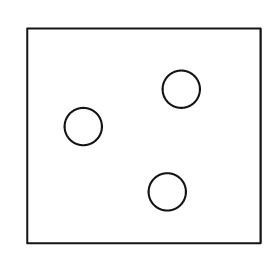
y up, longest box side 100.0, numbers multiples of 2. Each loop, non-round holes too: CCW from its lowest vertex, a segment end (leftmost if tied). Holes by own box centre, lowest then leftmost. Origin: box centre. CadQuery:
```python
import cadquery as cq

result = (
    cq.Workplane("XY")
    .moveTo(-50.0, -46.0)
    .lineTo(50.0, -46.0)
    .lineTo(50.0, 46.0)
    .lineTo(-50.0, 46.0)
    .close()
    .moveTo(10.0, -24.0)
    .circle(8.0)
    .moveTo(-26.0, 4.0)
    .circle(8.0)
    .moveTo(16.0, 20.0)
    .circle(8.0)
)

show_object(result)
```